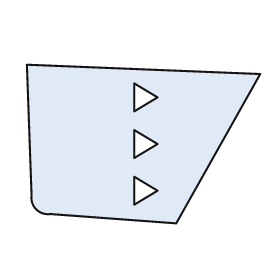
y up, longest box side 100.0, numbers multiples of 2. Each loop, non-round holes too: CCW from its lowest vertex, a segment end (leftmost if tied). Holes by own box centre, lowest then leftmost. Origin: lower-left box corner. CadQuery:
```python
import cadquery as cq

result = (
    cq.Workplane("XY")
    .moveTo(64.0, 0.0)
    .lineTo(100.0, 64.0)
    .lineTo(0.0, 68.0)
    .lineTo(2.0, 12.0)
    .threePointArc((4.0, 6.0), (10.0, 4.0))
    .close()
    .moveTo(46.0, 8.0)
    .lineTo(56.0, 14.0)
    .lineTo(46.0, 20.0)
    .close()
    .moveTo(46.0, 28.0)
    .lineTo(56.0, 34.0)
    .lineTo(46.0, 40.0)
    .close()
    .moveTo(46.0, 48.0)
    .lineTo(56.0, 54.0)
    .lineTo(46.0, 60.0)
    .close()
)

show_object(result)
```